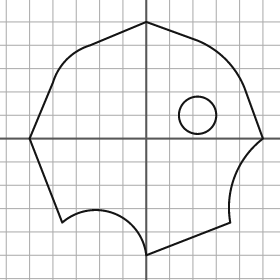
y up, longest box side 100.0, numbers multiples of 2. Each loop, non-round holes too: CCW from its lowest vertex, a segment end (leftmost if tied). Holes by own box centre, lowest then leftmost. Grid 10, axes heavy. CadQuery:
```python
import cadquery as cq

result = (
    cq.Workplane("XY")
    .moveTo(0.0, -50.0)
    .lineTo(36.0, -36.0)
    .threePointArc((38.0, -16.0), (50.0, 0.0))
    .lineTo(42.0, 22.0)
    .threePointArc((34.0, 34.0), (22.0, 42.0))
    .lineTo(0.0, 50.0)
    .lineTo(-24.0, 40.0)
    .threePointArc((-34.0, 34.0), (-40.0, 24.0))
    .lineTo(-50.0, 0.0)
    .lineTo(-36.0, -36.0)
    .threePointArc((-14.0, -32.0), (0.0, -50.0))
    .close()
    .moveTo(22.0, 10.0)
    .circle(8.0)
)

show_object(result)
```